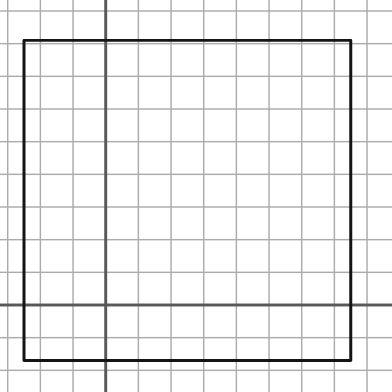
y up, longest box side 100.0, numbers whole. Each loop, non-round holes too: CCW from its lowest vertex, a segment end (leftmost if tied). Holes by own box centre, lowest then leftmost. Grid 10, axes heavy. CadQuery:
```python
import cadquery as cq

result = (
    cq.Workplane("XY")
    .moveTo(-25.0, -17.0)
    .lineTo(75.0, -17.0)
    .lineTo(75.0, 81.0)
    .lineTo(-25.0, 81.0)
    .close()
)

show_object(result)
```